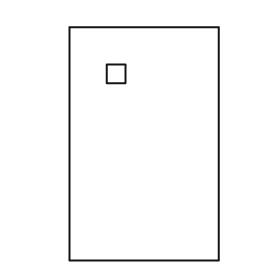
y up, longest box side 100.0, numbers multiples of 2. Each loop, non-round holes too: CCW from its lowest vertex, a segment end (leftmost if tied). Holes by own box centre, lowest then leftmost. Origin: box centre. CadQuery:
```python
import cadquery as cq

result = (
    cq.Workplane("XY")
    .moveTo(-32.0, -50.0)
    .lineTo(32.0, -50.0)
    .lineTo(32.0, 50.0)
    .lineTo(-32.0, 50.0)
    .close()
    .moveTo(-16.0, 26.0)
    .lineTo(-8.0, 26.0)
    .lineTo(-8.0, 34.0)
    .lineTo(-16.0, 34.0)
    .close()
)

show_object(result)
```